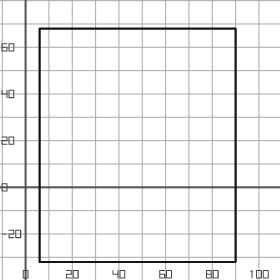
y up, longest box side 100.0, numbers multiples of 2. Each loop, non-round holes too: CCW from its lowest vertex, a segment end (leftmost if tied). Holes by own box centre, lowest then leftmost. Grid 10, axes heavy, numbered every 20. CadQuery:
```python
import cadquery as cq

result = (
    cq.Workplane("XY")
    .moveTo(6.0, -32.0)
    .lineTo(90.0, -32.0)
    .lineTo(90.0, 68.0)
    .lineTo(6.0, 68.0)
    .close()
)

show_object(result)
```